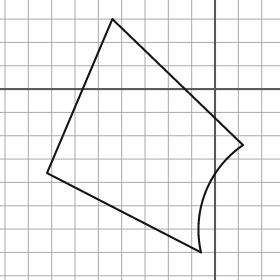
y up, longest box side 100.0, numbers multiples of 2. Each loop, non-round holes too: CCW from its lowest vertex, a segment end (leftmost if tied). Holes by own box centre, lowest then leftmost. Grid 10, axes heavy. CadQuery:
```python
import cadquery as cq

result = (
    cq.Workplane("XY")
    .moveTo(-6.0, -70.0)
    .threePointArc((-4.0, -44.0), (12.0, -24.0))
    .lineTo(-44.0, 30.0)
    .lineTo(-72.0, -36.0)
    .close()
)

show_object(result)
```